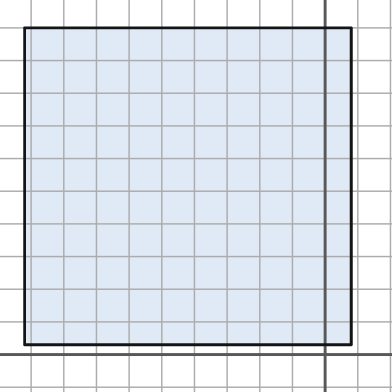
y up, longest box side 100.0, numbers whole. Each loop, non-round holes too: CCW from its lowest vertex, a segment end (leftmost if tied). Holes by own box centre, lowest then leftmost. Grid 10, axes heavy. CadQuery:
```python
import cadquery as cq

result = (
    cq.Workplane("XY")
    .moveTo(-92.0, 3.0)
    .lineTo(8.0, 3.0)
    .lineTo(8.0, 100.0)
    .lineTo(-92.0, 100.0)
    .close()
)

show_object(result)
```